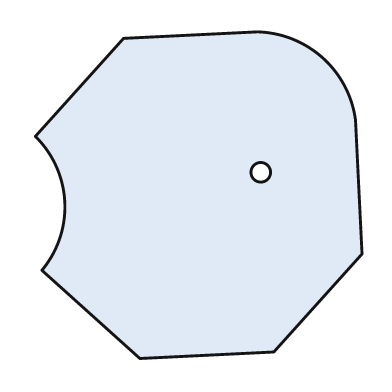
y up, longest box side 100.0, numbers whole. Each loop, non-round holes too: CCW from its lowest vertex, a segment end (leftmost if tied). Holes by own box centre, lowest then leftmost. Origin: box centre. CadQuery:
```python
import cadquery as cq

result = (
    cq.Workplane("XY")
    .moveTo(-18.0, -50.0)
    .lineTo(23.0, -48.0)
    .lineTo(50.0, -18.0)
    .lineTo(48.0, 23.0)
    .threePointArc((38.0, 42.0), (18.0, 50.0))
    .lineTo(-23.0, 48.0)
    .lineTo(-50.0, 18.0)
    .threePointArc((-41.0, -2.0), (-48.0, -23.0))
    .close()
    .moveTo(19.0, 7.0)
    .circle(3.0)
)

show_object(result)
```